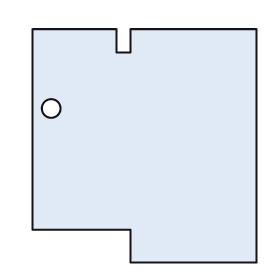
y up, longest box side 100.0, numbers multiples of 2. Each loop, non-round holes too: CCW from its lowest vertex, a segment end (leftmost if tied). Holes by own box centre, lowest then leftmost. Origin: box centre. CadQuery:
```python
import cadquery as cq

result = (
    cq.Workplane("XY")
    .moveTo(-6.0, -50.0)
    .lineTo(48.0, -50.0)
    .lineTo(48.0, 50.0)
    .lineTo(-6.0, 50.0)
    .lineTo(-6.0, 40.0)
    .lineTo(-12.0, 40.0)
    .lineTo(-12.0, 50.0)
    .lineTo(-48.0, 50.0)
    .lineTo(-48.0, -36.0)
    .lineTo(-6.0, -36.0)
    .close()
    .moveTo(-40.0, 16.0)
    .circle(4.0)
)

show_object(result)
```